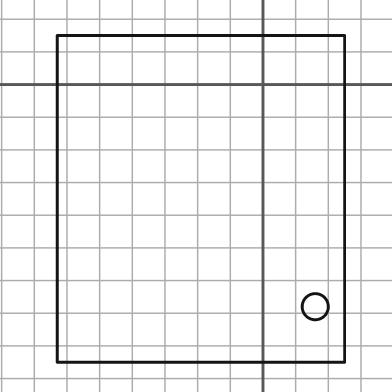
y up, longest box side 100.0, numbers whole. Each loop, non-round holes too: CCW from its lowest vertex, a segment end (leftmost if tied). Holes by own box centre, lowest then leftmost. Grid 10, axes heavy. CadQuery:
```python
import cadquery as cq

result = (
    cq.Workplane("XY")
    .moveTo(-63.0, -85.0)
    .lineTo(25.0, -85.0)
    .lineTo(25.0, 15.0)
    .lineTo(-63.0, 15.0)
    .close()
    .moveTo(16.0, -68.0)
    .circle(4.0)
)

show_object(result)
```